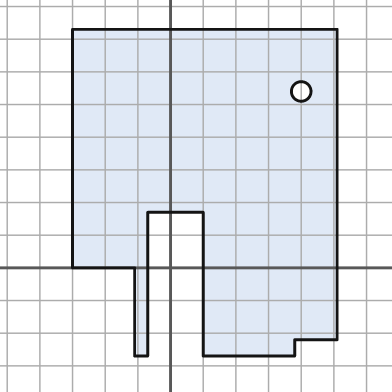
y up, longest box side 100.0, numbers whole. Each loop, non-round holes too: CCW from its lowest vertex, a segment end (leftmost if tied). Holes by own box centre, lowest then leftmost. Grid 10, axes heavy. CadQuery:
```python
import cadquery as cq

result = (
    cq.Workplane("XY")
    .moveTo(-11.0, -27.0)
    .lineTo(-7.0, -27.0)
    .lineTo(-7.0, 17.0)
    .lineTo(10.0, 17.0)
    .lineTo(10.0, -27.0)
    .lineTo(38.0, -27.0)
    .lineTo(38.0, -22.0)
    .lineTo(51.0, -22.0)
    .lineTo(51.0, 73.0)
    .lineTo(-30.0, 73.0)
    .lineTo(-30.0, 0.0)
    .lineTo(-11.0, 0.0)
    .close()
    .moveTo(40.0, 54.0)
    .circle(3.0)
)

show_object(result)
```